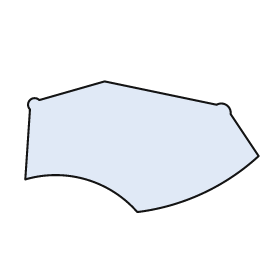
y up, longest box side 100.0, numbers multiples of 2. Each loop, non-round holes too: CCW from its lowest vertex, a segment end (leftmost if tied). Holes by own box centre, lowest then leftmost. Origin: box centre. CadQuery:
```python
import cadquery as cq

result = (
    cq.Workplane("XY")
    .moveTo(-2.0, -28.0)
    .threePointArc((26.0, -20.0), (50.0, -4.0))
    .lineTo(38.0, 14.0)
    .threePointArc((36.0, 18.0), (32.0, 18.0))
    .lineTo(-16.0, 28.0)
    .lineTo(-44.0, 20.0)
    .threePointArc((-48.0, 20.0), (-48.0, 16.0))
    .lineTo(-50.0, -14.0)
    .threePointArc((-24.0, -14.0), (-2.0, -28.0))
    .close()
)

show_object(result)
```